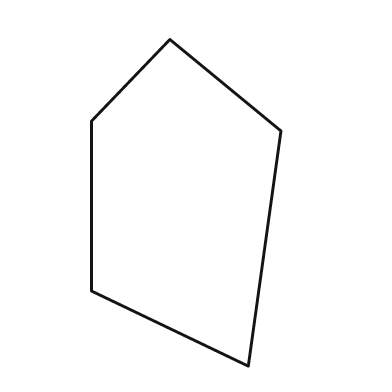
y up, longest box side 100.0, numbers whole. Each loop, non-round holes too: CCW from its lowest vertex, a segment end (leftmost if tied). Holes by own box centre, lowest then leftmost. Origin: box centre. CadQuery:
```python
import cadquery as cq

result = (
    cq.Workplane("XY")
    .moveTo(19.0, -50.0)
    .lineTo(29.0, 22.0)
    .lineTo(-5.0, 50.0)
    .lineTo(-29.0, 25.0)
    .lineTo(-29.0, -27.0)
    .close()
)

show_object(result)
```